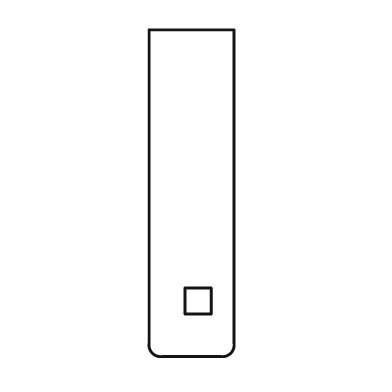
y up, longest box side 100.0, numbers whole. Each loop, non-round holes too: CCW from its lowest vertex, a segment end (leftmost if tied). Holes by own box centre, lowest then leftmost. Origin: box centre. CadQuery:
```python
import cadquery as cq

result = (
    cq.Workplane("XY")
    .moveTo(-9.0, -50.0)
    .lineTo(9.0, -50.0)
    .threePointArc((12.0, -49.0), (13.0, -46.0))
    .lineTo(13.0, 50.0)
    .lineTo(-13.0, 50.0)
    .lineTo(-13.0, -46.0)
    .threePointArc((-12.0, -49.0), (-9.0, -50.0))
    .close()
    .moveTo(-2.0, -37.0)
    .lineTo(6.0, -37.0)
    .lineTo(6.0, -29.0)
    .lineTo(-2.0, -29.0)
    .close()
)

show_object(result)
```